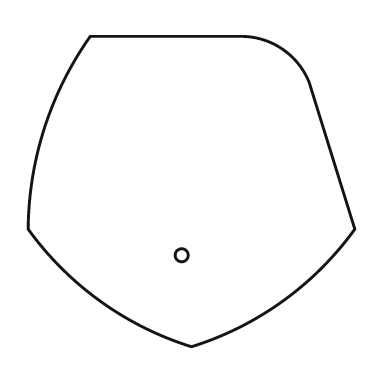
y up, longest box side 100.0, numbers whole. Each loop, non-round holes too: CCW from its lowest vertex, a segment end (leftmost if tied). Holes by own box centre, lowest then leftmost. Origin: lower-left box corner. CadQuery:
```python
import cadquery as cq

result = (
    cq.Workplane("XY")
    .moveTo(50.0, 0.0)
    .threePointArc((78.0, 14.0), (100.0, 36.0))
    .lineTo(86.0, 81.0)
    .threePointArc((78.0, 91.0), (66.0, 95.0))
    .lineTo(19.0, 95.0)
    .threePointArc((5.0, 67.0), (0.0, 36.0))
    .threePointArc((22.0, 14.0), (50.0, 0.0))
    .close()
    .moveTo(47.0, 28.0)
    .circle(2.0)
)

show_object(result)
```